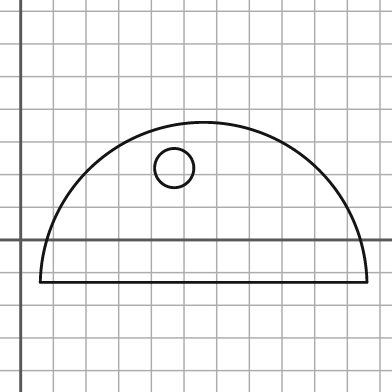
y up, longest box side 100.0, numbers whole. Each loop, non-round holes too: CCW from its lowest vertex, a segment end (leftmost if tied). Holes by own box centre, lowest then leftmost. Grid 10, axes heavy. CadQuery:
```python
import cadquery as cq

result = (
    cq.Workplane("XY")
    .moveTo(6.0, -13.0)
    .lineTo(106.0, -13.0)
    .threePointArc((56.0, 36.0), (6.0, -13.0))
    .close()
    .moveTo(47.0, 22.0)
    .circle(6.0)
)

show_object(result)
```